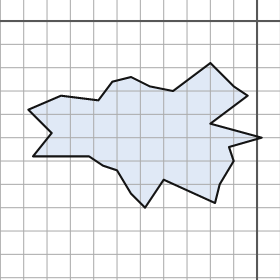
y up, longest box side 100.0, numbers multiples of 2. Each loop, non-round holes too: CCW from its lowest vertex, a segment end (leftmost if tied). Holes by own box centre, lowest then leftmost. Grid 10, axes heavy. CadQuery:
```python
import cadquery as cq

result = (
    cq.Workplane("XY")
    .moveTo(-48.0, -80.0)
    .lineTo(-40.0, -68.0)
    .lineTo(-18.0, -78.0)
    .lineTo(-16.0, -70.0)
    .lineTo(-10.0, -60.0)
    .lineTo(-12.0, -54.0)
    .lineTo(2.0, -50.0)
    .lineTo(-20.0, -44.0)
    .lineTo(-4.0, -32.0)
    .lineTo(-10.0, -28.0)
    .lineTo(-20.0, -18.0)
    .lineTo(-36.0, -30.0)
    .lineTo(-46.0, -28.0)
    .lineTo(-54.0, -24.0)
    .lineTo(-62.0, -26.0)
    .lineTo(-68.0, -34.0)
    .lineTo(-84.0, -32.0)
    .lineTo(-98.0, -38.0)
    .lineTo(-88.0, -48.0)
    .lineTo(-96.0, -58.0)
    .lineTo(-72.0, -58.0)
    .lineTo(-66.0, -62.0)
    .lineTo(-60.0, -64.0)
    .lineTo(-54.0, -74.0)
    .close()
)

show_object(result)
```